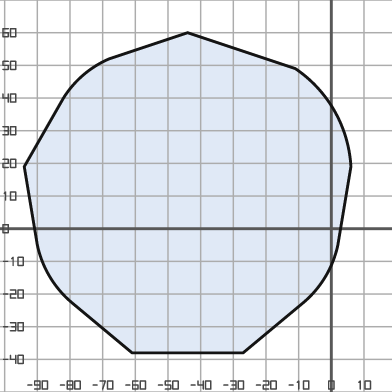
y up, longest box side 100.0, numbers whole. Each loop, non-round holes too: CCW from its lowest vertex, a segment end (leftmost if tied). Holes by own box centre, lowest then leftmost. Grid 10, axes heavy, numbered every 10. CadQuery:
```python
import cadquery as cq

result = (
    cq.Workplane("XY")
    .moveTo(-61.0, -38.0)
    .lineTo(-27.0, -38.0)
    .lineTo(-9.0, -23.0)
    .threePointArc((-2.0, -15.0), (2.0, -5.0))
    .lineTo(6.0, 19.0)
    .threePointArc((1.0, 36.0), (-11.0, 49.0))
    .lineTo(-44.0, 60.0)
    .lineTo(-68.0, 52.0)
    .threePointArc((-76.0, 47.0), (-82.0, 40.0))
    .lineTo(-94.0, 19.0)
    .lineTo(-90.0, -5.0)
    .threePointArc((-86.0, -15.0), (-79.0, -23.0))
    .close()
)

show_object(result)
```